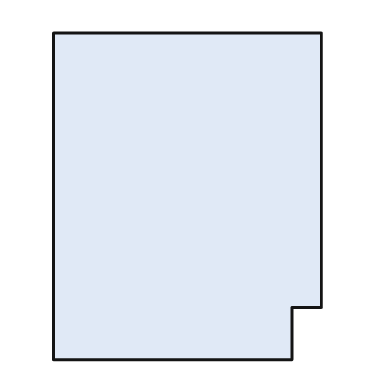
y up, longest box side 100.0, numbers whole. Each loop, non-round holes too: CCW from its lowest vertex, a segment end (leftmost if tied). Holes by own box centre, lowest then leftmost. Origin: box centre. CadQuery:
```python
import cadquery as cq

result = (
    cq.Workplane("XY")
    .moveTo(-41.0, -50.0)
    .lineTo(32.0, -50.0)
    .lineTo(32.0, -34.0)
    .lineTo(41.0, -34.0)
    .lineTo(41.0, 50.0)
    .lineTo(-41.0, 50.0)
    .close()
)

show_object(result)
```